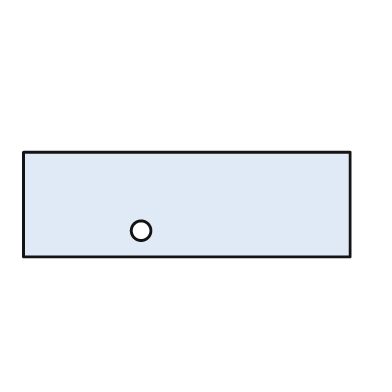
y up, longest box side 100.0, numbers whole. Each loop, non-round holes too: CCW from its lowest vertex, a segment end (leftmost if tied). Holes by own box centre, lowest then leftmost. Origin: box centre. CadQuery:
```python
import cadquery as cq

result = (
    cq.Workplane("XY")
    .moveTo(-50.0, -16.0)
    .lineTo(50.0, -16.0)
    .lineTo(50.0, 16.0)
    .lineTo(-50.0, 16.0)
    .close()
    .moveTo(-14.0, -8.0)
    .circle(3.0)
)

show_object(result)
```